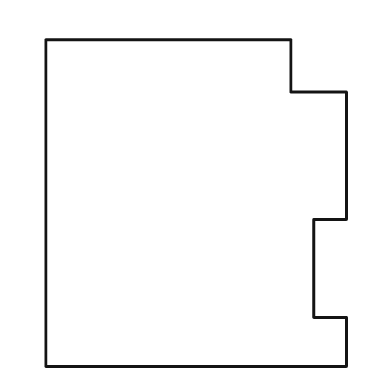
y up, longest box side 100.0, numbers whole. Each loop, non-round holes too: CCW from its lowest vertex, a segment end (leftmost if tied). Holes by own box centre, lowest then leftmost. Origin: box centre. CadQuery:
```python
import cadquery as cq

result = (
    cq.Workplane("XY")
    .moveTo(-46.0, -50.0)
    .lineTo(46.0, -50.0)
    .lineTo(46.0, -35.0)
    .lineTo(36.0, -35.0)
    .lineTo(36.0, -5.0)
    .lineTo(46.0, -5.0)
    .lineTo(46.0, 34.0)
    .lineTo(29.0, 34.0)
    .lineTo(29.0, 50.0)
    .lineTo(-46.0, 50.0)
    .close()
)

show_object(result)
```